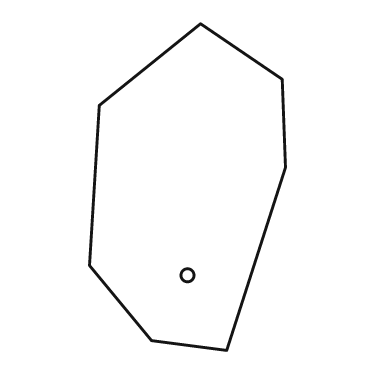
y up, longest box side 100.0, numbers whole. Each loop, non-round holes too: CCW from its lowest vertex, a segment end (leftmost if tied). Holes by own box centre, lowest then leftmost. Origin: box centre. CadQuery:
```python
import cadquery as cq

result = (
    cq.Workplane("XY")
    .moveTo(12.0, -50.0)
    .lineTo(30.0, 6.0)
    .lineTo(29.0, 33.0)
    .lineTo(4.0, 50.0)
    .lineTo(-27.0, 25.0)
    .lineTo(-30.0, -24.0)
    .lineTo(-11.0, -47.0)
    .close()
    .moveTo(0.0, -27.0)
    .circle(2.0)
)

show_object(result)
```